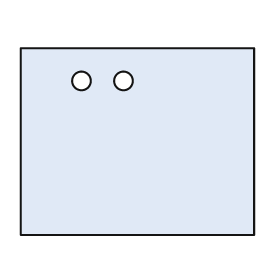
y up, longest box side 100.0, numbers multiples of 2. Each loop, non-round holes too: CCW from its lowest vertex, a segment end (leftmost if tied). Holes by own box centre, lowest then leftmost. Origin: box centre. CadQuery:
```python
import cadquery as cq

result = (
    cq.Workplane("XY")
    .moveTo(-50.0, -40.0)
    .lineTo(50.0, -40.0)
    .lineTo(50.0, 40.0)
    .lineTo(-50.0, 40.0)
    .close()
    .moveTo(-24.0, 26.0)
    .circle(4.0)
    .moveTo(-6.0, 26.0)
    .circle(4.0)
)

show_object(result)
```